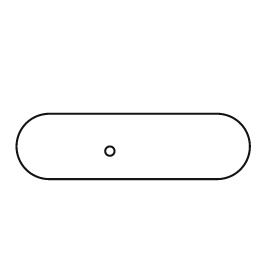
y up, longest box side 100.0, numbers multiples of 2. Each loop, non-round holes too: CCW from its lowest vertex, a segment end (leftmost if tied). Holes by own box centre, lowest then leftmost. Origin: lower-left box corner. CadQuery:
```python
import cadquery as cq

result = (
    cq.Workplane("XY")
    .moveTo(14.0, 0.0)
    .lineTo(86.0, 0.0)
    .threePointArc((100.0, 14.0), (86.0, 28.0))
    .lineTo(14.0, 28.0)
    .threePointArc((0.0, 14.0), (14.0, 0.0))
    .close()
    .moveTo(40.0, 12.0)
    .circle(2.0)
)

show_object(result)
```